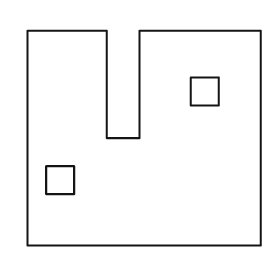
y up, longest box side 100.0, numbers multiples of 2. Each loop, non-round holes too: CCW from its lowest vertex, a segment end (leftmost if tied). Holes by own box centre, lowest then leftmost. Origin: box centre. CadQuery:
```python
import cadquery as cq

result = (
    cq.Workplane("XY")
    .moveTo(-50.0, -46.0)
    .lineTo(50.0, -46.0)
    .lineTo(50.0, 46.0)
    .lineTo(-2.0, 46.0)
    .lineTo(-2.0, 0.0)
    .lineTo(-16.0, 0.0)
    .lineTo(-16.0, 46.0)
    .lineTo(-50.0, 46.0)
    .close()
    .moveTo(-42.0, -24.0)
    .lineTo(-30.0, -24.0)
    .lineTo(-30.0, -12.0)
    .lineTo(-42.0, -12.0)
    .close()
    .moveTo(20.0, 14.0)
    .lineTo(32.0, 14.0)
    .lineTo(32.0, 26.0)
    .lineTo(20.0, 26.0)
    .close()
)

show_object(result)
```